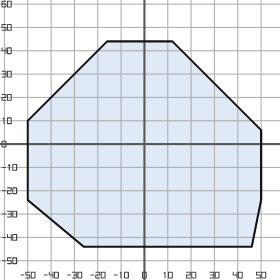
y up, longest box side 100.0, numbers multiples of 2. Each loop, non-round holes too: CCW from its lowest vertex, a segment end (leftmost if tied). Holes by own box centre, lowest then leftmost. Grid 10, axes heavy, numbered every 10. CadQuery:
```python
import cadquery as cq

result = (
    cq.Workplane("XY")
    .moveTo(-26.0, -44.0)
    .lineTo(46.0, -44.0)
    .lineTo(50.0, -24.0)
    .lineTo(50.0, 6.0)
    .lineTo(12.0, 44.0)
    .lineTo(-16.0, 44.0)
    .lineTo(-50.0, 10.0)
    .lineTo(-50.0, -24.0)
    .close()
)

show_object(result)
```